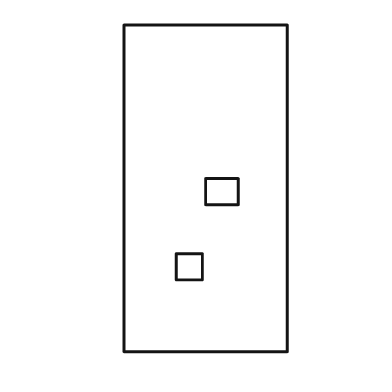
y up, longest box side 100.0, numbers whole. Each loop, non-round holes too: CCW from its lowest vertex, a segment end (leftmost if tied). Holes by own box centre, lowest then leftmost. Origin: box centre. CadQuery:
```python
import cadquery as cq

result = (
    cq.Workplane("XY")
    .moveTo(-25.0, -50.0)
    .lineTo(25.0, -50.0)
    .lineTo(25.0, 50.0)
    .lineTo(-25.0, 50.0)
    .close()
    .moveTo(-9.0, -28.0)
    .lineTo(-1.0, -28.0)
    .lineTo(-1.0, -20.0)
    .lineTo(-9.0, -20.0)
    .close()
    .moveTo(0.0, -5.0)
    .lineTo(10.0, -5.0)
    .lineTo(10.0, 3.0)
    .lineTo(0.0, 3.0)
    .close()
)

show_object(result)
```